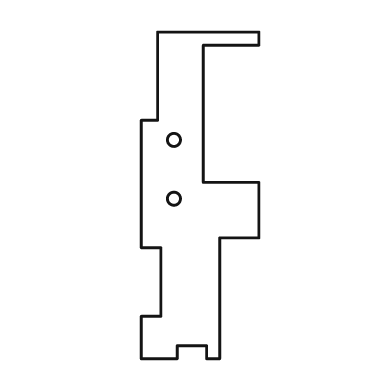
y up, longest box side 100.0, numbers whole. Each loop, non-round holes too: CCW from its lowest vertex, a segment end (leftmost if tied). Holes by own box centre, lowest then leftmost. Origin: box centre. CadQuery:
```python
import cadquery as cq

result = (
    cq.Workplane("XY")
    .moveTo(-18.0, -50.0)
    .lineTo(-7.0, -50.0)
    .lineTo(-7.0, -46.0)
    .lineTo(2.0, -46.0)
    .lineTo(2.0, -50.0)
    .lineTo(6.0, -50.0)
    .lineTo(6.0, -13.0)
    .lineTo(18.0, -13.0)
    .lineTo(18.0, 4.0)
    .lineTo(1.0, 4.0)
    .lineTo(1.0, 46.0)
    .lineTo(18.0, 46.0)
    .lineTo(18.0, 50.0)
    .lineTo(-13.0, 50.0)
    .lineTo(-13.0, 23.0)
    .lineTo(-18.0, 23.0)
    .lineTo(-18.0, -16.0)
    .lineTo(-12.0, -16.0)
    .lineTo(-12.0, -37.0)
    .lineTo(-18.0, -37.0)
    .close()
    .moveTo(-8.0, -1.0)
    .circle(2.0)
    .moveTo(-8.0, 17.0)
    .circle(2.0)
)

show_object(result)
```